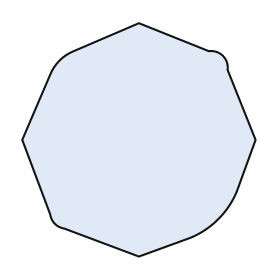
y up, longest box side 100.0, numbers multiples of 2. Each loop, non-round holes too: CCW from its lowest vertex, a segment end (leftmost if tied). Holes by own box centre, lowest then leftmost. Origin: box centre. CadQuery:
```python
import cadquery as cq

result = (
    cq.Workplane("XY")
    .moveTo(0.0, -50.0)
    .lineTo(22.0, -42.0)
    .threePointArc((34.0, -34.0), (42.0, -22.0))
    .lineTo(50.0, 0.0)
    .lineTo(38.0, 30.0)
    .threePointArc((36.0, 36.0), (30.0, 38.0))
    .lineTo(0.0, 50.0)
    .lineTo(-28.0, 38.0)
    .threePointArc((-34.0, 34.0), (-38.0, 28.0))
    .lineTo(-50.0, 0.0)
    .lineTo(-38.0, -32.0)
    .threePointArc((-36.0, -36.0), (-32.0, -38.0))
    .close()
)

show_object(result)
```